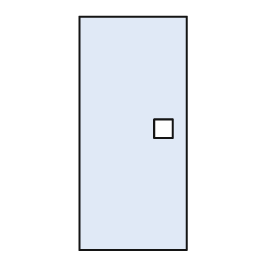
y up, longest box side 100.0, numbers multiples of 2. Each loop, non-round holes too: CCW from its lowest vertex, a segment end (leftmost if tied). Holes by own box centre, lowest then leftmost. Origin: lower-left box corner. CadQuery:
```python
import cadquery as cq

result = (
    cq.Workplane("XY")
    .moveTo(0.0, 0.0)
    .lineTo(46.0, 0.0)
    .lineTo(46.0, 100.0)
    .lineTo(0.0, 100.0)
    .close()
    .moveTo(32.0, 48.0)
    .lineTo(40.0, 48.0)
    .lineTo(40.0, 56.0)
    .lineTo(32.0, 56.0)
    .close()
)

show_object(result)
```